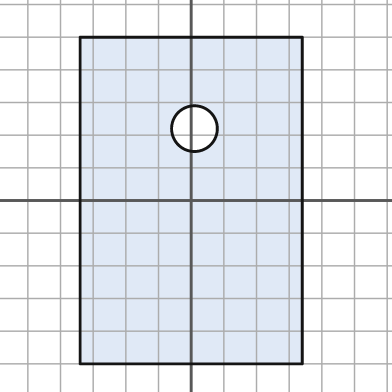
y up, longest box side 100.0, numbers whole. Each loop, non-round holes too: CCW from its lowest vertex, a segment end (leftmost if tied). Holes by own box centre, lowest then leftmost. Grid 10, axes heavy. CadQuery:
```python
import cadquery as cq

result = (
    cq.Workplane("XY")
    .moveTo(-34.0, -50.0)
    .lineTo(34.0, -50.0)
    .lineTo(34.0, 50.0)
    .lineTo(-34.0, 50.0)
    .close()
    .moveTo(1.0, 22.0)
    .circle(7.0)
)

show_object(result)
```